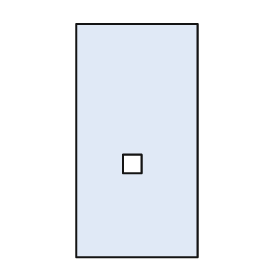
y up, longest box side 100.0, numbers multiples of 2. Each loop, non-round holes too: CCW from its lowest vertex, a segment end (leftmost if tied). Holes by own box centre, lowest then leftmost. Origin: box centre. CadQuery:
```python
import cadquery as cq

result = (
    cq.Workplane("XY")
    .moveTo(-26.0, -50.0)
    .lineTo(26.0, -50.0)
    .lineTo(26.0, 50.0)
    .lineTo(-26.0, 50.0)
    .close()
    .moveTo(-6.0, -14.0)
    .lineTo(2.0, -14.0)
    .lineTo(2.0, -6.0)
    .lineTo(-6.0, -6.0)
    .close()
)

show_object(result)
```